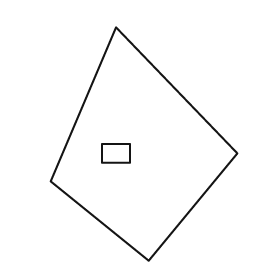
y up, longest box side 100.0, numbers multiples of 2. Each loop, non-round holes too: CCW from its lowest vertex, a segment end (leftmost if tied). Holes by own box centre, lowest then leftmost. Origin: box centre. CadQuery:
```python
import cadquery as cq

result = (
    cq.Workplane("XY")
    .moveTo(2.0, -50.0)
    .lineTo(40.0, -4.0)
    .lineTo(-12.0, 50.0)
    .lineTo(-40.0, -16.0)
    .close()
    .moveTo(-18.0, -8.0)
    .lineTo(-6.0, -8.0)
    .lineTo(-6.0, 0.0)
    .lineTo(-18.0, 0.0)
    .close()
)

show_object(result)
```